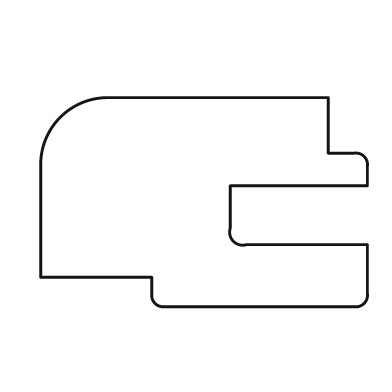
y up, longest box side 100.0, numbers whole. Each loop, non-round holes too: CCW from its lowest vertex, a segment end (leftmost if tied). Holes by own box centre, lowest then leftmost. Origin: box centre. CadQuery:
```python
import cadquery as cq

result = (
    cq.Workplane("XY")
    .moveTo(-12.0, -32.0)
    .lineTo(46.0, -32.0)
    .threePointArc((49.0, -31.0), (50.0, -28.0))
    .lineTo(50.0, -13.0)
    .lineTo(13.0, -13.0)
    .threePointArc((9.0, -12.0), (8.0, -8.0))
    .lineTo(8.0, 5.0)
    .lineTo(50.0, 5.0)
    .lineTo(50.0, 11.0)
    .threePointArc((49.0, 14.0), (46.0, 15.0))
    .lineTo(38.0, 15.0)
    .lineTo(38.0, 32.0)
    .lineTo(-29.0, 32.0)
    .threePointArc((-44.0, 26.0), (-50.0, 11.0))
    .lineTo(-50.0, -23.0)
    .lineTo(-16.0, -23.0)
    .lineTo(-16.0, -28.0)
    .threePointArc((-15.0, -31.0), (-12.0, -32.0))
    .close()
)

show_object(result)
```